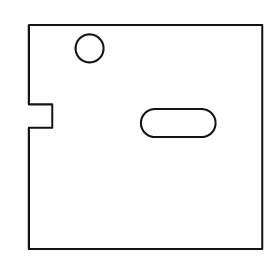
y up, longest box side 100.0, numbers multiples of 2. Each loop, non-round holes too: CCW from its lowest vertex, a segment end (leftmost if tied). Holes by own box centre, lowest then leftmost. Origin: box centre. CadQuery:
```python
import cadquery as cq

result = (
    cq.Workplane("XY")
    .moveTo(-50.0, -48.0)
    .lineTo(50.0, -48.0)
    .lineTo(50.0, 48.0)
    .lineTo(-50.0, 48.0)
    .lineTo(-50.0, 14.0)
    .lineTo(-40.0, 14.0)
    .lineTo(-40.0, 4.0)
    .lineTo(-50.0, 4.0)
    .close()
    .moveTo(4.0, 0.0)
    .lineTo(24.0, 0.0)
    .threePointArc((30.0, 6.0), (24.0, 12.0))
    .lineTo(4.0, 12.0)
    .threePointArc((-2.0, 6.0), (4.0, 0.0))
    .close()
    .moveTo(-24.0, 38.0)
    .circle(6.0)
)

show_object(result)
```